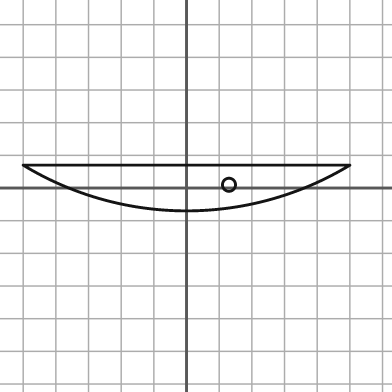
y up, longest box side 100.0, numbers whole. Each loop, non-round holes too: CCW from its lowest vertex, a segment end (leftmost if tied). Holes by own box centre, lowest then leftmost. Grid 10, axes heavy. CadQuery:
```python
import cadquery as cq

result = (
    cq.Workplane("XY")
    .moveTo(-50.0, 7.0)
    .threePointArc((0.0, -7.0), (50.0, 7.0))
    .close()
    .moveTo(13.0, 1.0)
    .circle(2.0)
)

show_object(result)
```